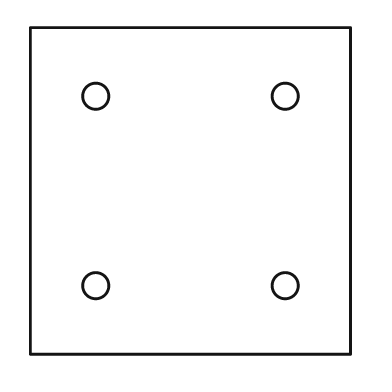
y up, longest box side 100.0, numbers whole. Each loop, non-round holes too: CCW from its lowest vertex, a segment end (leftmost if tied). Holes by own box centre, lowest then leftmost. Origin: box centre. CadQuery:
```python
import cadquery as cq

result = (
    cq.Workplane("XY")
    .moveTo(-49.0, -50.0)
    .lineTo(49.0, -50.0)
    .lineTo(49.0, 50.0)
    .lineTo(-49.0, 50.0)
    .close()
    .moveTo(-29.0, -29.0)
    .circle(4.0)
    .moveTo(29.0, -29.0)
    .circle(4.0)
    .moveTo(-29.0, 29.0)
    .circle(4.0)
    .moveTo(29.0, 29.0)
    .circle(4.0)
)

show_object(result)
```